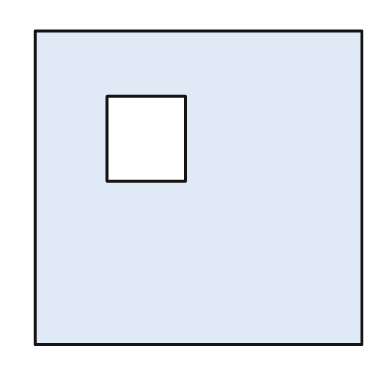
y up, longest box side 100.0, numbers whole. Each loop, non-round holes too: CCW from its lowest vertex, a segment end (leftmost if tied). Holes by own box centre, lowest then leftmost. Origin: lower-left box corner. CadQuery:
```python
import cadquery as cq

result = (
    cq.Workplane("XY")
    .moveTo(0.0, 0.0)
    .lineTo(100.0, 0.0)
    .lineTo(100.0, 96.0)
    .lineTo(0.0, 96.0)
    .close()
    .moveTo(22.0, 50.0)
    .lineTo(46.0, 50.0)
    .lineTo(46.0, 76.0)
    .lineTo(22.0, 76.0)
    .close()
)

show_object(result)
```